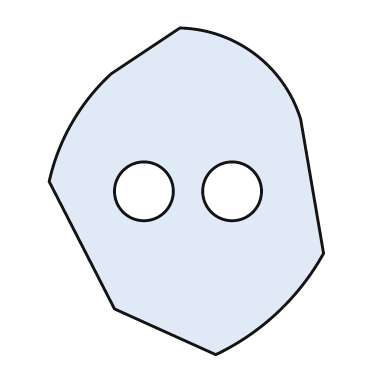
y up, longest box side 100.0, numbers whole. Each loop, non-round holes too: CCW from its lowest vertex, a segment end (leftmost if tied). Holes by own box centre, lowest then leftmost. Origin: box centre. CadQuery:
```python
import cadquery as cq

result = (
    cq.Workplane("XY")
    .moveTo(9.0, -50.0)
    .threePointArc((28.0, -37.0), (42.0, -19.0))
    .lineTo(35.0, 22.0)
    .threePointArc((21.0, 42.0), (-2.0, 50.0))
    .lineTo(-23.0, 36.0)
    .threePointArc((-35.0, 21.0), (-42.0, 3.0))
    .lineTo(-22.0, -36.0)
    .close()
    .moveTo(-13.0, 0.0)
    .circle(9.0)
    .moveTo(14.0, 0.0)
    .circle(9.0)
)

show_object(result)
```